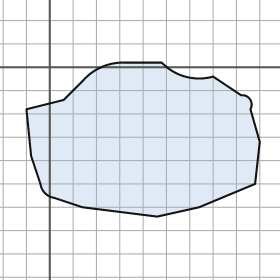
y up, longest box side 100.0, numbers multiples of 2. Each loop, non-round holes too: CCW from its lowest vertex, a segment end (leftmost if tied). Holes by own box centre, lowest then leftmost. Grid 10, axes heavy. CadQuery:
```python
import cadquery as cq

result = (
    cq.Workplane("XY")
    .moveTo(46.0, -64.0)
    .lineTo(64.0, -60.0)
    .lineTo(88.0, -50.0)
    .lineTo(90.0, -32.0)
    .lineTo(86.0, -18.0)
    .threePointArc((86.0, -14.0), (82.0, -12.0))
    .lineTo(70.0, -4.0)
    .threePointArc((58.0, -4.0), (48.0, 2.0))
    .lineTo(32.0, 2.0)
    .threePointArc((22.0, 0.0), (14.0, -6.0))
    .lineTo(6.0, -14.0)
    .lineTo(-10.0, -18.0)
    .lineTo(-8.0, -38.0)
    .lineTo(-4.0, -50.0)
    .threePointArc((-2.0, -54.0), (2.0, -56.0))
    .lineTo(14.0, -60.0)
    .close()
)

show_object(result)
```